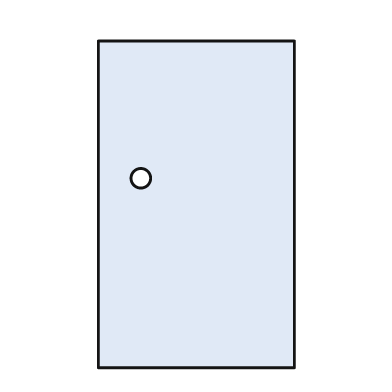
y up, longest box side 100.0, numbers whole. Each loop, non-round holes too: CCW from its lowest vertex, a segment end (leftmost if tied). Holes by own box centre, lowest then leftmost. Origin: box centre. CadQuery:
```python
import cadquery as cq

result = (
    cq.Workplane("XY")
    .moveTo(-30.0, -50.0)
    .lineTo(30.0, -50.0)
    .lineTo(30.0, 50.0)
    .lineTo(-30.0, 50.0)
    .close()
    .moveTo(-17.0, 8.0)
    .circle(3.0)
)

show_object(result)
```